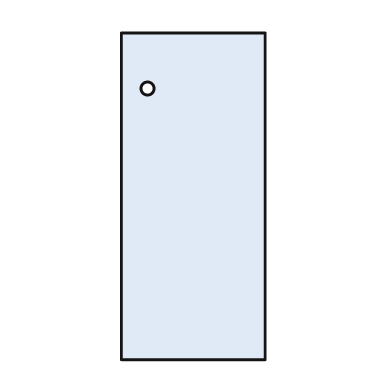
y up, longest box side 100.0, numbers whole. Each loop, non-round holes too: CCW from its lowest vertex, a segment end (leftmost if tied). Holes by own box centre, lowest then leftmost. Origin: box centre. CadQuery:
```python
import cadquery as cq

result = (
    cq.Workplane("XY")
    .moveTo(-22.0, -50.0)
    .lineTo(22.0, -50.0)
    .lineTo(22.0, 50.0)
    .lineTo(-22.0, 50.0)
    .close()
    .moveTo(-14.0, 33.0)
    .circle(2.0)
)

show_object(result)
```